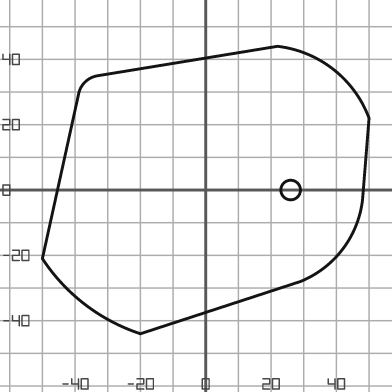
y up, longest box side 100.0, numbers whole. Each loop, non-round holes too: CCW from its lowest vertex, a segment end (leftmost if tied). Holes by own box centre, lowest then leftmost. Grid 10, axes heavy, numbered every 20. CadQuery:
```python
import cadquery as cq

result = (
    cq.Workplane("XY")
    .moveTo(-20.0, -44.0)
    .lineTo(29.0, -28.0)
    .threePointArc((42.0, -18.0), (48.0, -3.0))
    .lineTo(50.0, 22.0)
    .threePointArc((39.0, 37.0), (22.0, 44.0))
    .lineTo(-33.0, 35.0)
    .threePointArc((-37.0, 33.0), (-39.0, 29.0))
    .lineTo(-50.0, -21.0)
    .threePointArc((-37.0, -35.0), (-20.0, -44.0))
    .close()
    .moveTo(26.0, 0.0)
    .circle(3.0)
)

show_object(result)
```